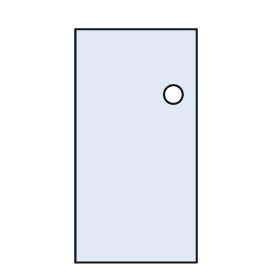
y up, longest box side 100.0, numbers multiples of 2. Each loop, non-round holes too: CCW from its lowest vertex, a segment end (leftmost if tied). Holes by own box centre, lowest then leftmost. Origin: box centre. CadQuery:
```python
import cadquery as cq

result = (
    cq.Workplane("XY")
    .moveTo(-26.0, -50.0)
    .lineTo(26.0, -50.0)
    .lineTo(26.0, 50.0)
    .lineTo(-26.0, 50.0)
    .close()
    .moveTo(16.0, 22.0)
    .circle(4.0)
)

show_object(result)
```